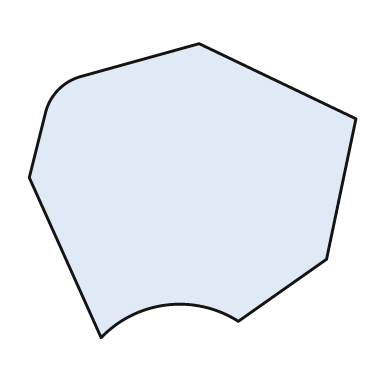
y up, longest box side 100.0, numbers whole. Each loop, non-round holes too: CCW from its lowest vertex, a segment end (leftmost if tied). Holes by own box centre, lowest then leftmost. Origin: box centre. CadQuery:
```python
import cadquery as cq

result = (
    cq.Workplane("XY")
    .moveTo(-28.0, -45.0)
    .threePointArc((-8.0, -35.0), (14.0, -40.0))
    .lineTo(41.0, -21.0)
    .lineTo(50.0, 22.0)
    .lineTo(2.0, 45.0)
    .lineTo(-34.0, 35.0)
    .threePointArc((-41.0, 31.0), (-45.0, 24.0))
    .lineTo(-50.0, 4.0)
    .close()
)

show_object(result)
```